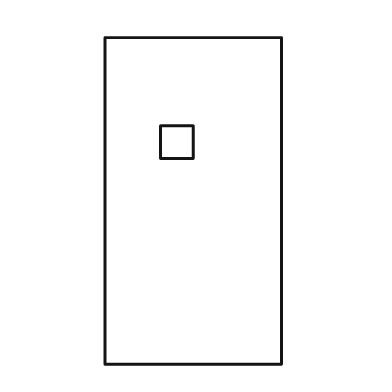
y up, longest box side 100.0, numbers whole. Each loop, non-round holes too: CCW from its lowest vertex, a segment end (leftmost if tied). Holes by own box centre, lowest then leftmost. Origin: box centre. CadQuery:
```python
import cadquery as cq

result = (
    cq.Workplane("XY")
    .moveTo(-27.0, -50.0)
    .lineTo(27.0, -50.0)
    .lineTo(27.0, 50.0)
    .lineTo(-27.0, 50.0)
    .close()
    .moveTo(-10.0, 13.0)
    .lineTo(0.0, 13.0)
    .lineTo(0.0, 23.0)
    .lineTo(-10.0, 23.0)
    .close()
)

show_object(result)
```